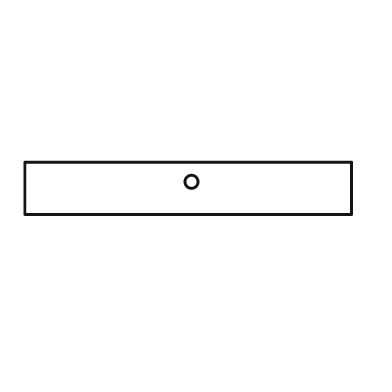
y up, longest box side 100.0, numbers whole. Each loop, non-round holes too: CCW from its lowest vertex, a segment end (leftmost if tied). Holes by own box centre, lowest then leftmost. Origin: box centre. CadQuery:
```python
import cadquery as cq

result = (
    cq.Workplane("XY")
    .moveTo(-50.0, -8.0)
    .lineTo(50.0, -8.0)
    .lineTo(50.0, 8.0)
    .lineTo(-50.0, 8.0)
    .close()
    .moveTo(1.0, 2.0)
    .circle(2.0)
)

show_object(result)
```